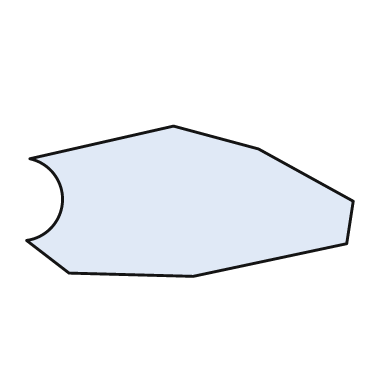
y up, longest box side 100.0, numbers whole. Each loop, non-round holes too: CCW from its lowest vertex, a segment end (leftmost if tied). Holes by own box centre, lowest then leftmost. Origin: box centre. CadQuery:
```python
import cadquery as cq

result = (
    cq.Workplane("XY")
    .moveTo(1.0, -23.0)
    .lineTo(48.0, -13.0)
    .lineTo(50.0, 0.0)
    .lineTo(21.0, 16.0)
    .lineTo(-5.0, 23.0)
    .lineTo(-49.0, 13.0)
    .threePointArc((-39.0, 0.0), (-50.0, -12.0))
    .lineTo(-37.0, -22.0)
    .close()
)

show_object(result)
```